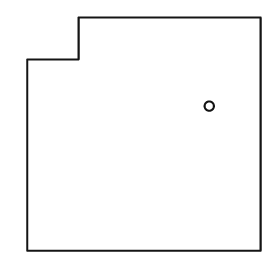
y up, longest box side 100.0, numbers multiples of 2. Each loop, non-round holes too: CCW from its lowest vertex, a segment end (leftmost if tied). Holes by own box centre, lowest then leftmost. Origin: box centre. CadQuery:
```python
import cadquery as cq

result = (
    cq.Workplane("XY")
    .moveTo(-50.0, -50.0)
    .lineTo(50.0, -50.0)
    .lineTo(50.0, 50.0)
    .lineTo(-28.0, 50.0)
    .lineTo(-28.0, 32.0)
    .lineTo(-50.0, 32.0)
    .close()
    .moveTo(28.0, 12.0)
    .circle(2.0)
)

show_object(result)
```